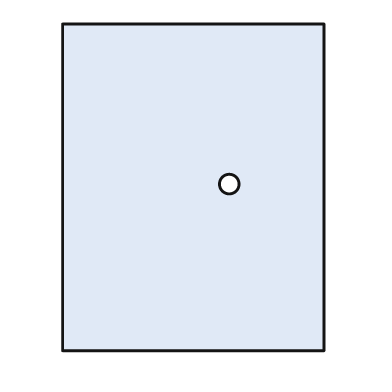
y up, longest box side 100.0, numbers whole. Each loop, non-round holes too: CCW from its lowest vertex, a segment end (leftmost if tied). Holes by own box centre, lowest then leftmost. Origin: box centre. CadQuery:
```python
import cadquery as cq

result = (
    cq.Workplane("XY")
    .moveTo(-40.0, -50.0)
    .lineTo(40.0, -50.0)
    .lineTo(40.0, 50.0)
    .lineTo(-40.0, 50.0)
    .close()
    .moveTo(11.0, 1.0)
    .circle(3.0)
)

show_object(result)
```